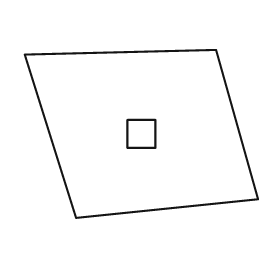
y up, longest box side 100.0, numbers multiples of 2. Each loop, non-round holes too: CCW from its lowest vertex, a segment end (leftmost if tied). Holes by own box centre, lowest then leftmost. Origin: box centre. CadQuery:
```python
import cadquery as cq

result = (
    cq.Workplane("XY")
    .moveTo(-28.0, -36.0)
    .lineTo(50.0, -28.0)
    .lineTo(32.0, 36.0)
    .lineTo(-50.0, 34.0)
    .close()
    .moveTo(-6.0, -6.0)
    .lineTo(6.0, -6.0)
    .lineTo(6.0, 6.0)
    .lineTo(-6.0, 6.0)
    .close()
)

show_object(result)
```